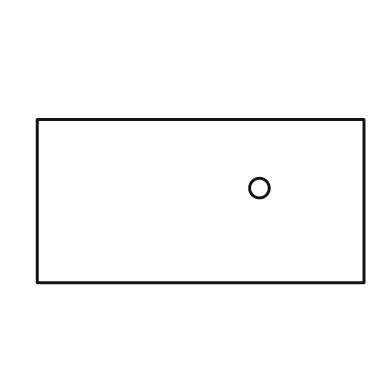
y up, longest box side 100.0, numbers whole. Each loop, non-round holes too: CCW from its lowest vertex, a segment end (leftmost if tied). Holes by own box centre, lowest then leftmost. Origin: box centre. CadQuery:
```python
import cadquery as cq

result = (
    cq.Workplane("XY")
    .moveTo(-50.0, -25.0)
    .lineTo(50.0, -25.0)
    .lineTo(50.0, 25.0)
    .lineTo(-50.0, 25.0)
    .close()
    .moveTo(18.0, 4.0)
    .circle(3.0)
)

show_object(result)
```